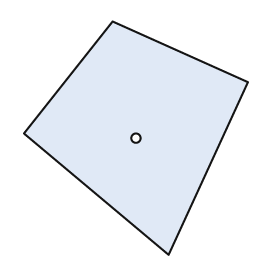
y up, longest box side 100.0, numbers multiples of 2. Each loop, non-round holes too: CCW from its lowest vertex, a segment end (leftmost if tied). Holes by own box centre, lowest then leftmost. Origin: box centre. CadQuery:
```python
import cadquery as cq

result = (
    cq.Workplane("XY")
    .moveTo(14.0, -50.0)
    .lineTo(48.0, 24.0)
    .lineTo(-10.0, 50.0)
    .lineTo(-48.0, 2.0)
    .close()
    .moveTo(0.0, 0.0)
    .circle(2.0)
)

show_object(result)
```